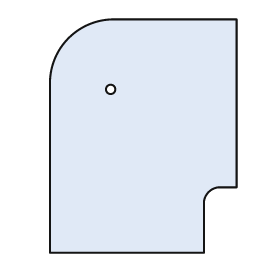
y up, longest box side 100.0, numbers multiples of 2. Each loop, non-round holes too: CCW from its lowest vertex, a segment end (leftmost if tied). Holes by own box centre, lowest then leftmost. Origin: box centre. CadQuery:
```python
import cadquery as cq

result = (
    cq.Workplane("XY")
    .moveTo(-40.0, -50.0)
    .lineTo(26.0, -50.0)
    .lineTo(26.0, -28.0)
    .threePointArc((28.0, -24.0), (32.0, -22.0))
    .lineTo(40.0, -22.0)
    .lineTo(40.0, 50.0)
    .lineTo(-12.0, 50.0)
    .threePointArc((-32.0, 42.0), (-40.0, 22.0))
    .close()
    .moveTo(-14.0, 20.0)
    .circle(2.0)
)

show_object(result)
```